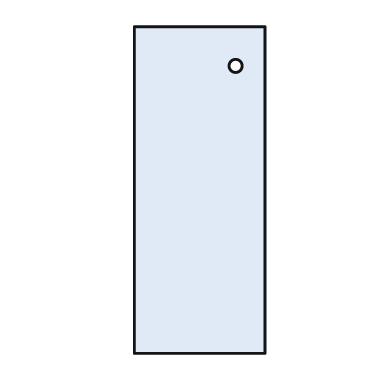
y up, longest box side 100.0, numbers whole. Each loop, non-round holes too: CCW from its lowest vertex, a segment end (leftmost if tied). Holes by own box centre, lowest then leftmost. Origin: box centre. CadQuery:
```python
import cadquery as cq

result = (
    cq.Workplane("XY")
    .moveTo(-20.0, -50.0)
    .lineTo(20.0, -50.0)
    .lineTo(20.0, 50.0)
    .lineTo(-20.0, 50.0)
    .close()
    .moveTo(11.0, 38.0)
    .circle(2.0)
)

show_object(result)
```